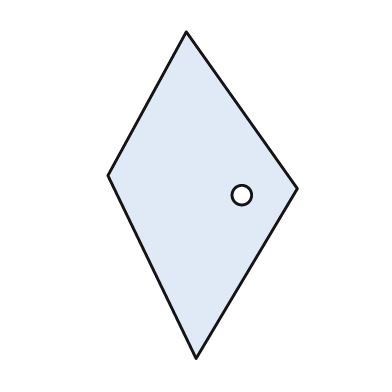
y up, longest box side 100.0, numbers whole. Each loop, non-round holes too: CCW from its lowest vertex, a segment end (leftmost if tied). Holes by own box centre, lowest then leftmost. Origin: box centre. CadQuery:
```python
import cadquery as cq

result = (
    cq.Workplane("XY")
    .moveTo(-2.0, -50.0)
    .lineTo(29.0, 2.0)
    .lineTo(-5.0, 50.0)
    .lineTo(-29.0, 6.0)
    .close()
    .moveTo(12.0, 0.0)
    .circle(3.0)
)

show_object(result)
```